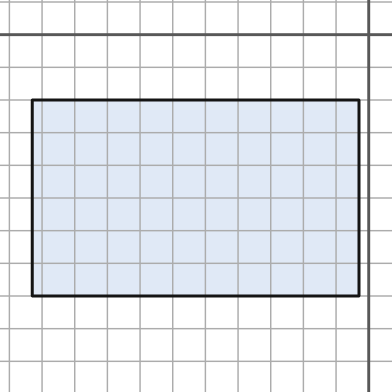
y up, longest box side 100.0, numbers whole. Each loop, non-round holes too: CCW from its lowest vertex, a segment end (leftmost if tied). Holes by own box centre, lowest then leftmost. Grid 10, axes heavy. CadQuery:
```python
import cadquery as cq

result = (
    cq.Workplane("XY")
    .moveTo(-103.0, -80.0)
    .lineTo(-3.0, -80.0)
    .lineTo(-3.0, -20.0)
    .lineTo(-103.0, -20.0)
    .close()
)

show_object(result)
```